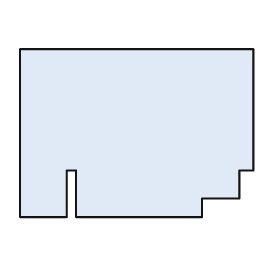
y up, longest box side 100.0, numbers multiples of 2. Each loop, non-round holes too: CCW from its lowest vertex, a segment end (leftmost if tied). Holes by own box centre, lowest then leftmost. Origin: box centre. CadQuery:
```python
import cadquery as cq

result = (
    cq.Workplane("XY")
    .moveTo(-50.0, -36.0)
    .lineTo(-30.0, -36.0)
    .lineTo(-30.0, -16.0)
    .lineTo(-26.0, -16.0)
    .lineTo(-26.0, -36.0)
    .lineTo(28.0, -36.0)
    .lineTo(28.0, -28.0)
    .lineTo(44.0, -28.0)
    .lineTo(44.0, -16.0)
    .lineTo(50.0, -16.0)
    .lineTo(50.0, 36.0)
    .lineTo(-50.0, 36.0)
    .close()
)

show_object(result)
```